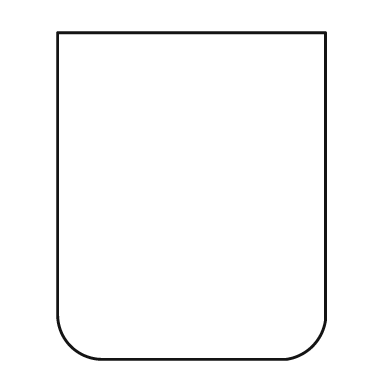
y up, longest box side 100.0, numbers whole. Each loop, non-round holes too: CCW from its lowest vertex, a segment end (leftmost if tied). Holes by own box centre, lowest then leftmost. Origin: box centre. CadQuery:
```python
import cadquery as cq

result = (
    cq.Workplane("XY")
    .moveTo(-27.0, -50.0)
    .lineTo(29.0, -50.0)
    .threePointArc((37.0, -46.0), (41.0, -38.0))
    .lineTo(41.0, 50.0)
    .lineTo(-41.0, 50.0)
    .lineTo(-41.0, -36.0)
    .threePointArc((-37.0, -46.0), (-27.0, -50.0))
    .close()
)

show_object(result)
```